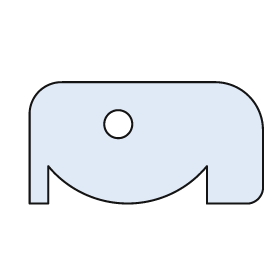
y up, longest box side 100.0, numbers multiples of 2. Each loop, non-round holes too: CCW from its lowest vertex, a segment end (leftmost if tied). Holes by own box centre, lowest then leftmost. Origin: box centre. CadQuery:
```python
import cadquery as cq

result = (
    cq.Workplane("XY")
    .moveTo(-50.0, -26.0)
    .lineTo(-42.0, -26.0)
    .lineTo(-42.0, -10.0)
    .threePointArc((-8.0, -26.0), (26.0, -10.0))
    .lineTo(26.0, -26.0)
    .lineTo(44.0, -26.0)
    .threePointArc((48.0, -24.0), (50.0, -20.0))
    .lineTo(50.0, 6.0)
    .threePointArc((44.0, 20.0), (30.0, 26.0))
    .lineTo(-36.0, 26.0)
    .threePointArc((-46.0, 22.0), (-50.0, 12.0))
    .close()
    .moveTo(-12.0, 8.0)
    .circle(6.0)
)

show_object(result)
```